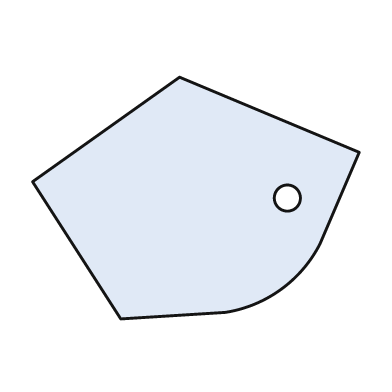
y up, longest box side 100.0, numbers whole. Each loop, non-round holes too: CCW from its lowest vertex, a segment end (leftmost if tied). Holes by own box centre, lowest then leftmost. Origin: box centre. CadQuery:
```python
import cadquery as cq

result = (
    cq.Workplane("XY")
    .moveTo(-23.0, -37.0)
    .lineTo(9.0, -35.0)
    .threePointArc((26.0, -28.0), (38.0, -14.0))
    .lineTo(50.0, 14.0)
    .lineTo(-5.0, 37.0)
    .lineTo(-50.0, 5.0)
    .close()
    .moveTo(28.0, 0.0)
    .circle(4.0)
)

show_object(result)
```